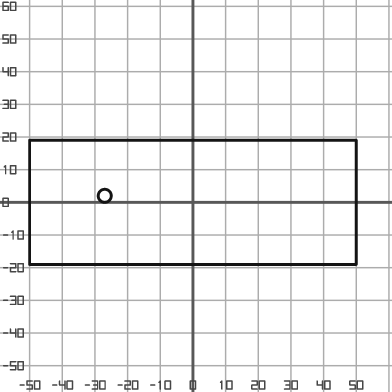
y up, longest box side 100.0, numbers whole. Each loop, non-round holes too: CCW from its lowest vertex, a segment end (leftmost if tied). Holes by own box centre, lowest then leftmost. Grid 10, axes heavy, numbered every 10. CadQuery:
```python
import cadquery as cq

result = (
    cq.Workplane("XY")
    .moveTo(-50.0, -19.0)
    .lineTo(50.0, -19.0)
    .lineTo(50.0, 19.0)
    .lineTo(-50.0, 19.0)
    .close()
    .moveTo(-27.0, 2.0)
    .circle(2.0)
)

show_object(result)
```